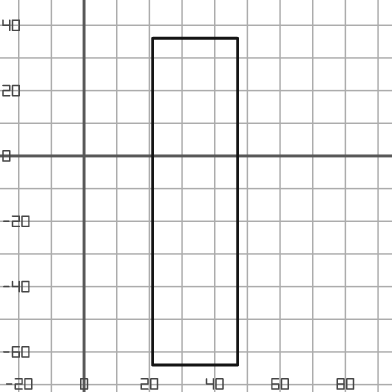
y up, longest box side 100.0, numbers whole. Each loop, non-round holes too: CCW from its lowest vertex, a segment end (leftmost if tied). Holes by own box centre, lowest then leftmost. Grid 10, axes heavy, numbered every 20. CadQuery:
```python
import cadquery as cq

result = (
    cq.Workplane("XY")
    .moveTo(21.0, -64.0)
    .lineTo(47.0, -64.0)
    .lineTo(47.0, 36.0)
    .lineTo(21.0, 36.0)
    .close()
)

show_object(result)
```